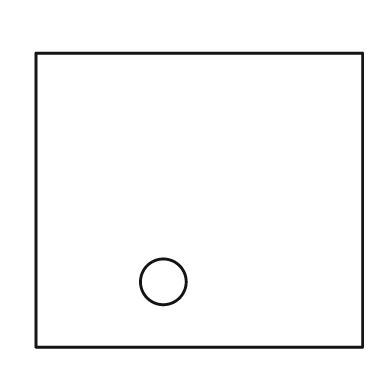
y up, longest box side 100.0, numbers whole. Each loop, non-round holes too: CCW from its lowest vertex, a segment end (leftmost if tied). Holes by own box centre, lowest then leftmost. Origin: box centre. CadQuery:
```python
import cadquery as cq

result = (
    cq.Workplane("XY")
    .moveTo(-50.0, -45.0)
    .lineTo(50.0, -45.0)
    .lineTo(50.0, 45.0)
    .lineTo(-50.0, 45.0)
    .close()
    .moveTo(-11.0, -25.0)
    .circle(7.0)
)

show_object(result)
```